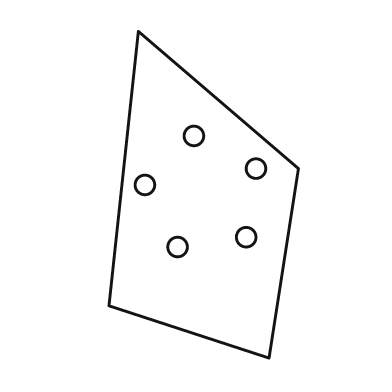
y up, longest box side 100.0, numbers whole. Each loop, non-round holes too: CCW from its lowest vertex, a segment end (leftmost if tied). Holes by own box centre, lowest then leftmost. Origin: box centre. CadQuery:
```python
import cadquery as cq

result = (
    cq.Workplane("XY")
    .moveTo(20.0, -50.0)
    .lineTo(29.0, 8.0)
    .lineTo(-20.0, 50.0)
    .lineTo(-29.0, -34.0)
    .close()
    .moveTo(-8.0, -16.0)
    .circle(3.0)
    .moveTo(13.0, -13.0)
    .circle(3.0)
    .moveTo(-18.0, 3.0)
    .circle(3.0)
    .moveTo(16.0, 8.0)
    .circle(3.0)
    .moveTo(-3.0, 18.0)
    .circle(3.0)
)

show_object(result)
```